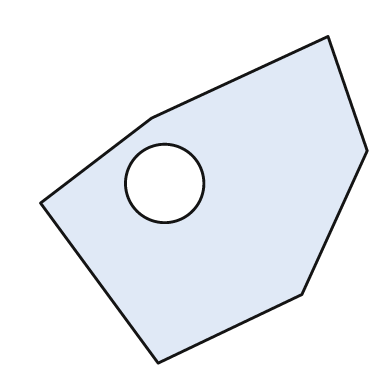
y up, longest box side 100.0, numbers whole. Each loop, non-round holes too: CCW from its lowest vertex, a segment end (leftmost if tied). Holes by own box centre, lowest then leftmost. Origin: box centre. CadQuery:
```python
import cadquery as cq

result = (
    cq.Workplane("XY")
    .moveTo(-14.0, -50.0)
    .lineTo(30.0, -29.0)
    .lineTo(50.0, 15.0)
    .lineTo(38.0, 50.0)
    .lineTo(-16.0, 25.0)
    .lineTo(-50.0, -1.0)
    .close()
    .moveTo(-12.0, 5.0)
    .circle(12.0)
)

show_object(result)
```